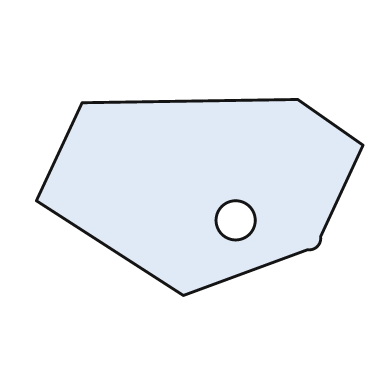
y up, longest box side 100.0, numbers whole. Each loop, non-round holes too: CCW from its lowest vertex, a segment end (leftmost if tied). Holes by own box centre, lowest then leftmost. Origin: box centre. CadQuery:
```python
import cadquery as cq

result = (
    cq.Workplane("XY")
    .moveTo(-5.0, -30.0)
    .lineTo(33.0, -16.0)
    .threePointArc((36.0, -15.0), (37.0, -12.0))
    .lineTo(50.0, 16.0)
    .lineTo(30.0, 30.0)
    .lineTo(-36.0, 29.0)
    .lineTo(-50.0, -1.0)
    .close()
    .moveTo(11.0, -7.0)
    .circle(6.0)
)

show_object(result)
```